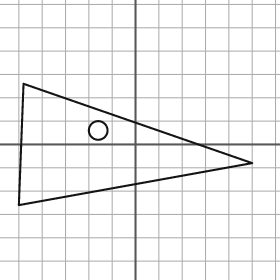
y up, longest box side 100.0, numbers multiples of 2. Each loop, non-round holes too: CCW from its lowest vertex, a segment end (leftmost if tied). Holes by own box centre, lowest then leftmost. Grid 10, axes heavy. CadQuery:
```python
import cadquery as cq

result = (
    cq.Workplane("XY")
    .moveTo(-50.0, -26.0)
    .lineTo(50.0, -8.0)
    .lineTo(-48.0, 26.0)
    .close()
    .moveTo(-16.0, 6.0)
    .circle(4.0)
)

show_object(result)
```